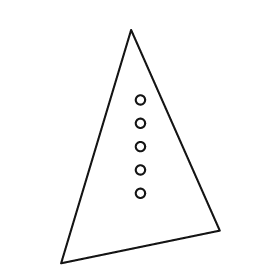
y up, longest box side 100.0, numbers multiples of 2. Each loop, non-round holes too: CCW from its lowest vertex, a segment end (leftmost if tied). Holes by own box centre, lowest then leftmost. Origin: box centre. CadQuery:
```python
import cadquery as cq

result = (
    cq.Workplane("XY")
    .moveTo(-34.0, -50.0)
    .lineTo(34.0, -36.0)
    .lineTo(-4.0, 50.0)
    .close()
    .moveTo(0.0, -20.0)
    .circle(2.0)
    .moveTo(0.0, -10.0)
    .circle(2.0)
    .moveTo(0.0, 0.0)
    .circle(2.0)
    .moveTo(0.0, 10.0)
    .circle(2.0)
    .moveTo(0.0, 20.0)
    .circle(2.0)
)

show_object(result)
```